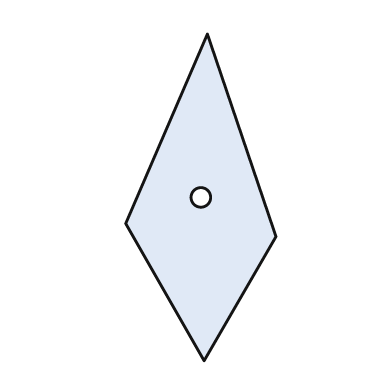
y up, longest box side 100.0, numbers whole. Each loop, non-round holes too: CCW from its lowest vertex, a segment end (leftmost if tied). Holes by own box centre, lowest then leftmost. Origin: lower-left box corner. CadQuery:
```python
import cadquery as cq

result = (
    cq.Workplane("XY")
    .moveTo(24.0, 0.0)
    .lineTo(46.0, 38.0)
    .lineTo(25.0, 100.0)
    .lineTo(0.0, 42.0)
    .close()
    .moveTo(23.0, 50.0)
    .circle(3.0)
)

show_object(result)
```